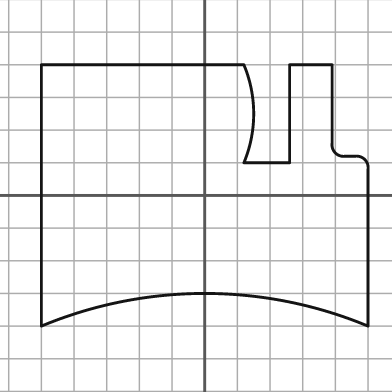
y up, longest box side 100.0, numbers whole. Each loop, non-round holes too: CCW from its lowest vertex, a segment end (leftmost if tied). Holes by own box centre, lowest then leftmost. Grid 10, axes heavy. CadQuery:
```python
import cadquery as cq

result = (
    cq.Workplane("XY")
    .moveTo(-50.0, -40.0)
    .threePointArc((0.0, -30.0), (50.0, -40.0))
    .lineTo(50.0, 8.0)
    .threePointArc((49.0, 11.0), (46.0, 12.0))
    .lineTo(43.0, 12.0)
    .threePointArc((40.0, 13.0), (39.0, 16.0))
    .lineTo(39.0, 40.0)
    .lineTo(26.0, 40.0)
    .lineTo(26.0, 10.0)
    .lineTo(12.0, 10.0)
    .threePointArc((15.0, 25.0), (12.0, 40.0))
    .lineTo(-50.0, 40.0)
    .close()
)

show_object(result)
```